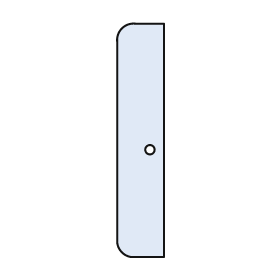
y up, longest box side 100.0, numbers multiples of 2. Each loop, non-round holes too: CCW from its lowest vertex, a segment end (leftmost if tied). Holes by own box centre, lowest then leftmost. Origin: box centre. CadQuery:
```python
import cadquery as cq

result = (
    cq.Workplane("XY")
    .moveTo(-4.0, -50.0)
    .lineTo(10.0, -50.0)
    .lineTo(10.0, 50.0)
    .lineTo(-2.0, 50.0)
    .threePointArc((-8.0, 48.0), (-10.0, 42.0))
    .lineTo(-10.0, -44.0)
    .threePointArc((-8.0, -48.0), (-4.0, -50.0))
    .close()
    .moveTo(4.0, -4.0)
    .circle(2.0)
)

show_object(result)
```